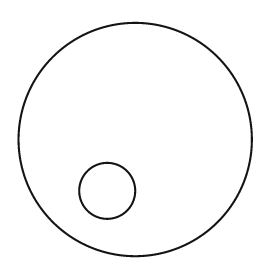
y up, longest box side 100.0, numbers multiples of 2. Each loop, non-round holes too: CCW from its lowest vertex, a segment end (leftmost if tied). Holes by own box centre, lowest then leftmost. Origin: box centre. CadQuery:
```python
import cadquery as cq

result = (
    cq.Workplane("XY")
    .moveTo(0.0, 0.0)
    .circle(50.0)
    .moveTo(-12.0, -22.0)
    .circle(12.0)
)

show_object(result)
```